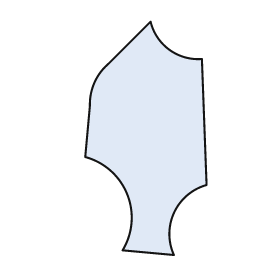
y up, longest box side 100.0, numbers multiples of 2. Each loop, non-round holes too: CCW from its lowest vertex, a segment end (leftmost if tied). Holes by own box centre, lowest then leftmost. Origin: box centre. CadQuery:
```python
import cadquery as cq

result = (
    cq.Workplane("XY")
    .moveTo(12.0, -50.0)
    .threePointArc((12.0, -32.0), (26.0, -20.0))
    .lineTo(24.0, 34.0)
    .threePointArc((10.0, 38.0), (2.0, 50.0))
    .lineTo(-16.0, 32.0)
    .threePointArc((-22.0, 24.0), (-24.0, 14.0))
    .lineTo(-26.0, -8.0)
    .threePointArc((-8.0, -24.0), (-10.0, -48.0))
    .close()
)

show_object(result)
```